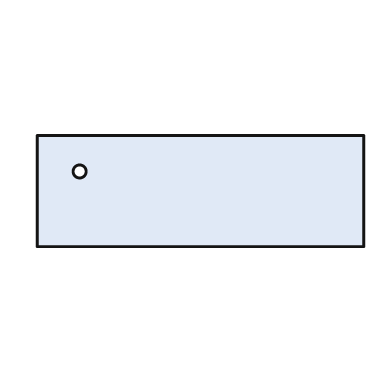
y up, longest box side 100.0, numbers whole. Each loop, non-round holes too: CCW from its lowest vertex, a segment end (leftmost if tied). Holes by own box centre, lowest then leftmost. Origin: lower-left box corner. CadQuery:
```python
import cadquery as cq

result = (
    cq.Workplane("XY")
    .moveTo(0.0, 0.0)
    .lineTo(100.0, 0.0)
    .lineTo(100.0, 34.0)
    .lineTo(0.0, 34.0)
    .close()
    .moveTo(13.0, 23.0)
    .circle(2.0)
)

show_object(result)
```